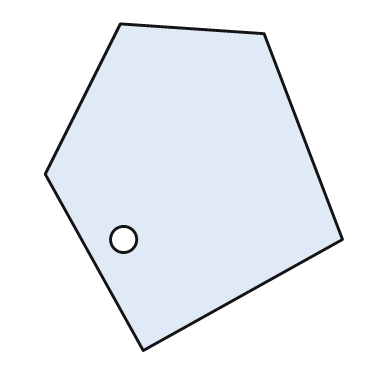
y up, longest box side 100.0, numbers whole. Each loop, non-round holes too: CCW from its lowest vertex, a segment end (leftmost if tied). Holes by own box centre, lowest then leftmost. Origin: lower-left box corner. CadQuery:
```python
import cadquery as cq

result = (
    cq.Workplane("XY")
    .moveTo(30.0, 0.0)
    .lineTo(91.0, 34.0)
    .lineTo(67.0, 97.0)
    .lineTo(23.0, 100.0)
    .lineTo(0.0, 54.0)
    .close()
    .moveTo(24.0, 34.0)
    .circle(4.0)
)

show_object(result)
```